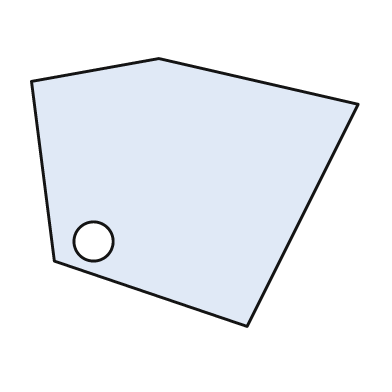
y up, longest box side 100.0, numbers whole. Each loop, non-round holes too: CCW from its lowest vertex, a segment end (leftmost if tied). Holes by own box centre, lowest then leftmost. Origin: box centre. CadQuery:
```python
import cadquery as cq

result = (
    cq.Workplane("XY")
    .moveTo(16.0, -41.0)
    .lineTo(50.0, 27.0)
    .lineTo(-11.0, 41.0)
    .lineTo(-50.0, 34.0)
    .lineTo(-43.0, -21.0)
    .close()
    .moveTo(-31.0, -15.0)
    .circle(6.0)
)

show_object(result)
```